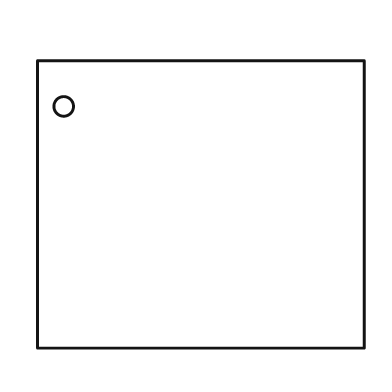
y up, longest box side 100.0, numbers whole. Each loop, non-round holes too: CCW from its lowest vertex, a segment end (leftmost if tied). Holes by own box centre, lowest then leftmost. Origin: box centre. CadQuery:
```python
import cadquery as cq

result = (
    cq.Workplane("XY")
    .moveTo(-50.0, -44.0)
    .lineTo(50.0, -44.0)
    .lineTo(50.0, 44.0)
    .lineTo(-50.0, 44.0)
    .close()
    .moveTo(-42.0, 30.0)
    .circle(3.0)
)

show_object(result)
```